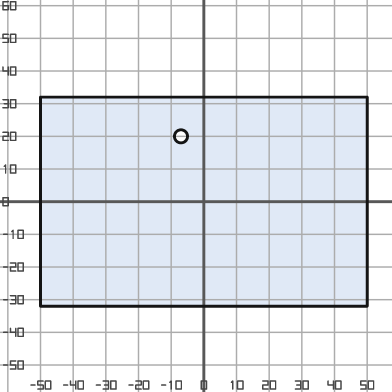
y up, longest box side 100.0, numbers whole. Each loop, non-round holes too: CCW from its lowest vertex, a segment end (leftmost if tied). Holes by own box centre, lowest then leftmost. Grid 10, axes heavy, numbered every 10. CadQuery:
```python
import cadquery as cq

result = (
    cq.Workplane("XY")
    .moveTo(-50.0, -32.0)
    .lineTo(50.0, -32.0)
    .lineTo(50.0, 32.0)
    .lineTo(-50.0, 32.0)
    .close()
    .moveTo(-7.0, 20.0)
    .circle(2.0)
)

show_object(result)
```